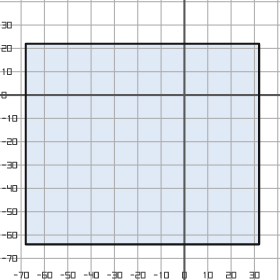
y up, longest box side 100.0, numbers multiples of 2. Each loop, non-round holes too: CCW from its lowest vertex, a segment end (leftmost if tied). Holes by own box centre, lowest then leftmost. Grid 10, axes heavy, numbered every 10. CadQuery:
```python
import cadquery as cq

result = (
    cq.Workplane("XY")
    .moveTo(-68.0, -64.0)
    .lineTo(32.0, -64.0)
    .lineTo(32.0, 22.0)
    .lineTo(-68.0, 22.0)
    .close()
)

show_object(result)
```